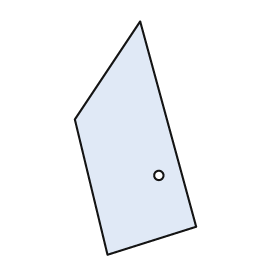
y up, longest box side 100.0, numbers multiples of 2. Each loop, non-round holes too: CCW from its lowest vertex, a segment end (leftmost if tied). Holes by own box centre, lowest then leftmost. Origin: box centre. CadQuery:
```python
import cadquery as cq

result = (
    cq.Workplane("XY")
    .moveTo(-12.0, -50.0)
    .lineTo(26.0, -38.0)
    .lineTo(2.0, 50.0)
    .lineTo(-26.0, 8.0)
    .close()
    .moveTo(10.0, -16.0)
    .circle(2.0)
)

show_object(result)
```